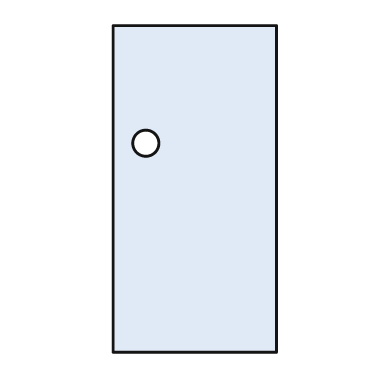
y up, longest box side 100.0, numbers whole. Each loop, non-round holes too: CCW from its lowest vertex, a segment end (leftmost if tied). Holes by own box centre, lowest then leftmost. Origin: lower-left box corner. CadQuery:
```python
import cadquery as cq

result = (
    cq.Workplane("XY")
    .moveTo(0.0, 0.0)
    .lineTo(50.0, 0.0)
    .lineTo(50.0, 100.0)
    .lineTo(0.0, 100.0)
    .close()
    .moveTo(10.0, 64.0)
    .circle(4.0)
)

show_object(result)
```